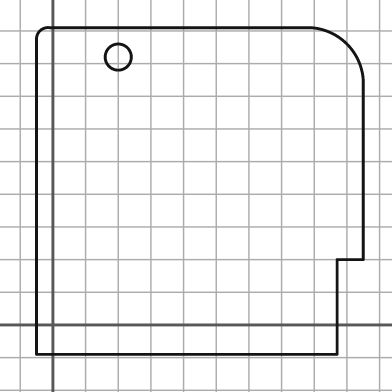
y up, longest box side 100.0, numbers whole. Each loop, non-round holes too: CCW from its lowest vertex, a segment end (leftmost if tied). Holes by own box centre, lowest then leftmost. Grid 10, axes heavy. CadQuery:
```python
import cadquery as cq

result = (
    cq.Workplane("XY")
    .moveTo(-5.0, -9.0)
    .lineTo(87.0, -9.0)
    .lineTo(87.0, 20.0)
    .lineTo(95.0, 20.0)
    .lineTo(95.0, 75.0)
    .threePointArc((90.0, 86.0), (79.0, 91.0))
    .lineTo(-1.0, 91.0)
    .threePointArc((-4.0, 90.0), (-5.0, 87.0))
    .close()
    .moveTo(20.0, 82.0)
    .circle(4.0)
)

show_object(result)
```